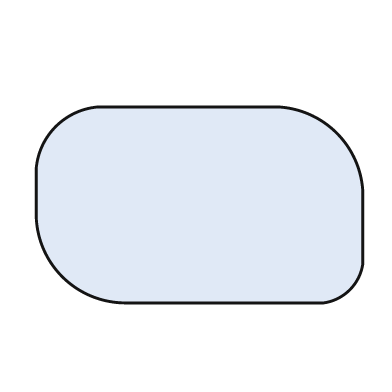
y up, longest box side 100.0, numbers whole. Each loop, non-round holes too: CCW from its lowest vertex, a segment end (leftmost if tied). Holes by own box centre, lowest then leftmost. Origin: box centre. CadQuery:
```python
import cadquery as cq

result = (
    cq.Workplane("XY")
    .moveTo(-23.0, -30.0)
    .lineTo(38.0, -30.0)
    .threePointArc((46.0, -26.0), (50.0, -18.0))
    .lineTo(50.0, 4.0)
    .threePointArc((42.0, 22.0), (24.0, 30.0))
    .lineTo(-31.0, 30.0)
    .threePointArc((-44.0, 24.0), (-50.0, 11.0))
    .lineTo(-50.0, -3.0)
    .threePointArc((-42.0, -22.0), (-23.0, -30.0))
    .close()
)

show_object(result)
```